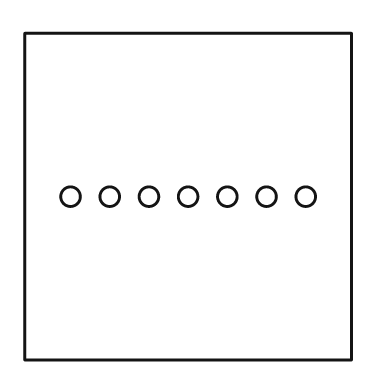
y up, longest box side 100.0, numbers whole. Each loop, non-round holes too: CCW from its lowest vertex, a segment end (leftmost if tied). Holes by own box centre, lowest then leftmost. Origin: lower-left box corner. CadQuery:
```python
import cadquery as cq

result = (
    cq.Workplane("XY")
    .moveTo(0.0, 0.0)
    .lineTo(100.0, 0.0)
    .lineTo(100.0, 100.0)
    .lineTo(0.0, 100.0)
    .close()
    .moveTo(14.0, 50.0)
    .circle(3.0)
    .moveTo(26.0, 50.0)
    .circle(3.0)
    .moveTo(38.0, 50.0)
    .circle(3.0)
    .moveTo(50.0, 50.0)
    .circle(3.0)
    .moveTo(62.0, 50.0)
    .circle(3.0)
    .moveTo(74.0, 50.0)
    .circle(3.0)
    .moveTo(86.0, 50.0)
    .circle(3.0)
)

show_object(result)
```